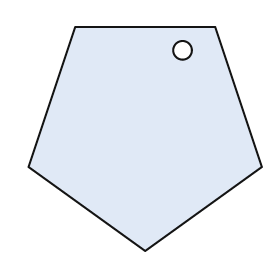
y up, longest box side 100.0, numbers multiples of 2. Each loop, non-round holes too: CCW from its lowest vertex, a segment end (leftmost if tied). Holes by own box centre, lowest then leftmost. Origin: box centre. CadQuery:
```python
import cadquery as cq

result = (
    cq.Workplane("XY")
    .moveTo(0.0, -48.0)
    .lineTo(50.0, -12.0)
    .lineTo(30.0, 48.0)
    .lineTo(-30.0, 48.0)
    .lineTo(-50.0, -12.0)
    .close()
    .moveTo(16.0, 38.0)
    .circle(4.0)
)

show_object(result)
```